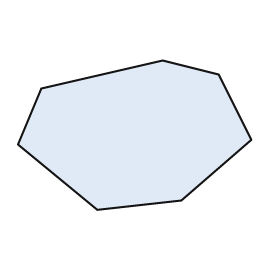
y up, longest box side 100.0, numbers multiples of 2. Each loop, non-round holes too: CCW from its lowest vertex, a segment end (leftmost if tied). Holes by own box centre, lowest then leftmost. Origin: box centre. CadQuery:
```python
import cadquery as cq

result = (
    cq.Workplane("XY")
    .moveTo(-16.0, -32.0)
    .lineTo(20.0, -28.0)
    .lineTo(50.0, -2.0)
    .lineTo(36.0, 26.0)
    .lineTo(12.0, 32.0)
    .lineTo(-40.0, 20.0)
    .lineTo(-50.0, -4.0)
    .close()
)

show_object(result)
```